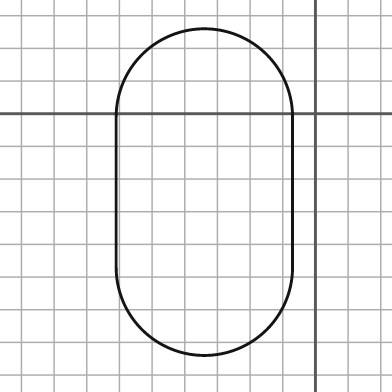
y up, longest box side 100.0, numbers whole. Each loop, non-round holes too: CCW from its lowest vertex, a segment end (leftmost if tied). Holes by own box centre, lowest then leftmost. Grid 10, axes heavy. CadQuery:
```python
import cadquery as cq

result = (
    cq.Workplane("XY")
    .moveTo(-61.0, -47.0)
    .threePointArc((-34.0, -74.0), (-7.0, -47.0))
    .lineTo(-7.0, -1.0)
    .threePointArc((-34.0, 26.0), (-61.0, -1.0))
    .close()
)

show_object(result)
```